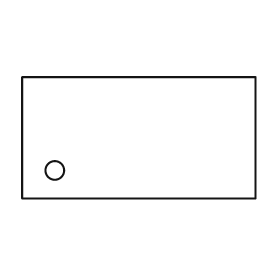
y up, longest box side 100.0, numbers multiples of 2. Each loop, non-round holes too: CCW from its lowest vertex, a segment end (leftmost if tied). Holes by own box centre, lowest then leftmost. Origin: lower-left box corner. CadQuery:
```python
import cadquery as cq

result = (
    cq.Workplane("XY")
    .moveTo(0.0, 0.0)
    .lineTo(100.0, 0.0)
    .lineTo(100.0, 52.0)
    .lineTo(0.0, 52.0)
    .close()
    .moveTo(14.0, 12.0)
    .circle(4.0)
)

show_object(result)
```